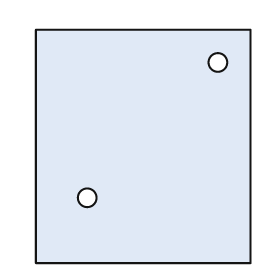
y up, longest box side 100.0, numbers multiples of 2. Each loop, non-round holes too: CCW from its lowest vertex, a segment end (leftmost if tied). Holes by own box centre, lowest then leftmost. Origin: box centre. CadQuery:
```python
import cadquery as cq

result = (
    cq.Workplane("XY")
    .moveTo(-46.0, -50.0)
    .lineTo(46.0, -50.0)
    .lineTo(46.0, 50.0)
    .lineTo(-46.0, 50.0)
    .close()
    .moveTo(-24.0, -22.0)
    .circle(4.0)
    .moveTo(32.0, 36.0)
    .circle(4.0)
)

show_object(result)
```